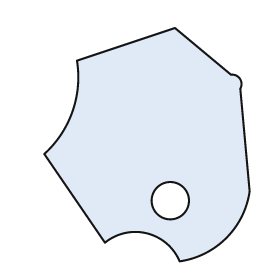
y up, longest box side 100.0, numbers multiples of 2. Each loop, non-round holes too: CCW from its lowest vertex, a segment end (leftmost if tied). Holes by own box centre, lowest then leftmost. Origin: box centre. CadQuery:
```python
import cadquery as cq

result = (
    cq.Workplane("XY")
    .moveTo(14.0, -50.0)
    .threePointArc((34.0, -40.0), (44.0, -20.0))
    .lineTo(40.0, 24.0)
    .threePointArc((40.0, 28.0), (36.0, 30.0))
    .lineTo(12.0, 50.0)
    .lineTo(-30.0, 36.0)
    .threePointArc((-32.0, 14.0), (-44.0, -4.0))
    .lineTo(-18.0, -42.0)
    .threePointArc((0.0, -38.0), (14.0, -50.0))
    .close()
    .moveTo(10.0, -24.0)
    .circle(8.0)
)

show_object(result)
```